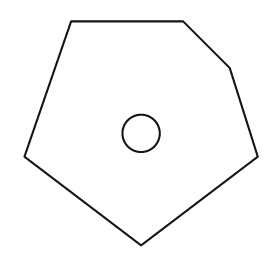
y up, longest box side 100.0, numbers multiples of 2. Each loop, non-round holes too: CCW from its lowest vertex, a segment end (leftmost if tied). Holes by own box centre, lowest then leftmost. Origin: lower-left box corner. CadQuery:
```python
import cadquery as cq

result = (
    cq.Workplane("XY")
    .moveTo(50.0, 0.0)
    .lineTo(100.0, 38.0)
    .lineTo(88.0, 76.0)
    .lineTo(68.0, 96.0)
    .lineTo(20.0, 96.0)
    .lineTo(0.0, 38.0)
    .close()
    .moveTo(50.0, 48.0)
    .circle(8.0)
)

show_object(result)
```